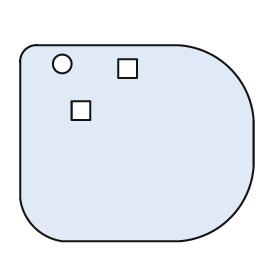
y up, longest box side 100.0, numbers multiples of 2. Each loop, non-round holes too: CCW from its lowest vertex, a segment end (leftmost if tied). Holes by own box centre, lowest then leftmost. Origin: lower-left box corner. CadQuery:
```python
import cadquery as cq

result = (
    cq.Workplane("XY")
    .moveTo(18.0, 0.0)
    .lineTo(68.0, 0.0)
    .threePointArc((90.0, 10.0), (100.0, 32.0))
    .lineTo(100.0, 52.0)
    .threePointArc((90.0, 74.0), (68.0, 84.0))
    .lineTo(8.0, 84.0)
    .threePointArc((2.0, 82.0), (0.0, 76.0))
    .lineTo(0.0, 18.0)
    .threePointArc((6.0, 6.0), (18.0, 0.0))
    .close()
    .moveTo(22.0, 52.0)
    .lineTo(30.0, 52.0)
    .lineTo(30.0, 60.0)
    .lineTo(22.0, 60.0)
    .close()
    .moveTo(42.0, 70.0)
    .lineTo(50.0, 70.0)
    .lineTo(50.0, 78.0)
    .lineTo(42.0, 78.0)
    .close()
    .moveTo(18.0, 76.0)
    .circle(4.0)
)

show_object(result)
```